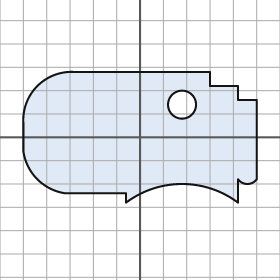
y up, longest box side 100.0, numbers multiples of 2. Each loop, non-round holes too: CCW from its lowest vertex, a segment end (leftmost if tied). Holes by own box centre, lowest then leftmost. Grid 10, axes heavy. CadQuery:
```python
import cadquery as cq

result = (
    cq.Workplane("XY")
    .moveTo(-6.0, -28.0)
    .threePointArc((18.0, -20.0), (42.0, -28.0))
    .lineTo(42.0, -18.0)
    .threePointArc((46.0, -20.0), (50.0, -18.0))
    .lineTo(50.0, 16.0)
    .lineTo(42.0, 16.0)
    .lineTo(42.0, 22.0)
    .lineTo(30.0, 22.0)
    .lineTo(30.0, 28.0)
    .lineTo(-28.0, 28.0)
    .threePointArc((-44.0, 22.0), (-50.0, 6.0))
    .lineTo(-50.0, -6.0)
    .threePointArc((-44.0, -18.0), (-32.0, -24.0))
    .lineTo(-6.0, -24.0)
    .close()
    .moveTo(18.0, 14.0)
    .circle(6.0)
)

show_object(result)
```